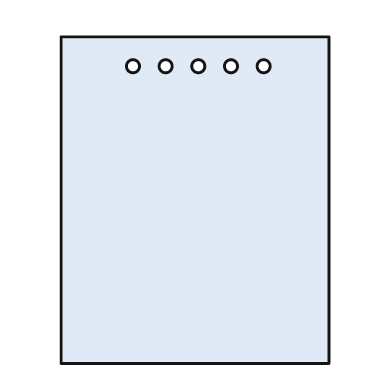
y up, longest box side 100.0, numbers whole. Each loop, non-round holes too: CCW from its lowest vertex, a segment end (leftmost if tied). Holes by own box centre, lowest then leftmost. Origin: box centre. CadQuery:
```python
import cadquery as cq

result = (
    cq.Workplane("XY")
    .moveTo(-41.0, -50.0)
    .lineTo(41.0, -50.0)
    .lineTo(41.0, 50.0)
    .lineTo(-41.0, 50.0)
    .close()
    .moveTo(-19.0, 41.0)
    .circle(2.0)
    .moveTo(-9.0, 41.0)
    .circle(2.0)
    .moveTo(1.0, 41.0)
    .circle(2.0)
    .moveTo(11.0, 41.0)
    .circle(2.0)
    .moveTo(21.0, 41.0)
    .circle(2.0)
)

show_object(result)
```